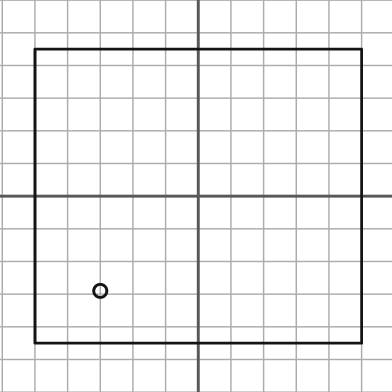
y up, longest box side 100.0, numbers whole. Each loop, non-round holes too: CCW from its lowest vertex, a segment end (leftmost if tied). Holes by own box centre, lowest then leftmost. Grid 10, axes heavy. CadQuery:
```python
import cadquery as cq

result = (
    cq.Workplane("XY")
    .moveTo(-50.0, -45.0)
    .lineTo(50.0, -45.0)
    .lineTo(50.0, 45.0)
    .lineTo(-50.0, 45.0)
    .close()
    .moveTo(-30.0, -29.0)
    .circle(2.0)
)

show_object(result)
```